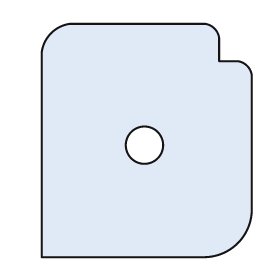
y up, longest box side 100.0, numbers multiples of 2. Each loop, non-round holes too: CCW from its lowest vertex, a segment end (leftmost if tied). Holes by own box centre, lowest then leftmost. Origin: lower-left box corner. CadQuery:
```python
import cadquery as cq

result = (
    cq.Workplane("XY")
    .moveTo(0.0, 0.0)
    .lineTo(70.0, 0.0)
    .threePointArc((84.0, 6.0), (90.0, 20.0))
    .lineTo(90.0, 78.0)
    .threePointArc((88.0, 82.0), (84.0, 84.0))
    .lineTo(76.0, 84.0)
    .lineTo(76.0, 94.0)
    .threePointArc((74.0, 98.0), (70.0, 100.0))
    .lineTo(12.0, 100.0)
    .threePointArc((4.0, 96.0), (0.0, 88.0))
    .close()
    .moveTo(44.0, 48.0)
    .circle(8.0)
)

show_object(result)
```